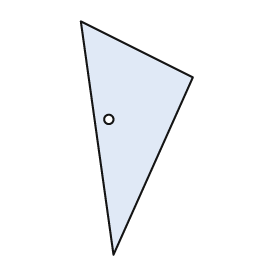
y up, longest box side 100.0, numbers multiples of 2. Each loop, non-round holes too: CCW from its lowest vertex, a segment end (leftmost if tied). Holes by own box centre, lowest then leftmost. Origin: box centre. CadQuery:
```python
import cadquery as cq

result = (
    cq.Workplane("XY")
    .moveTo(-10.0, -50.0)
    .lineTo(24.0, 26.0)
    .lineTo(-24.0, 50.0)
    .close()
    .moveTo(-12.0, 8.0)
    .circle(2.0)
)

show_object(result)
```